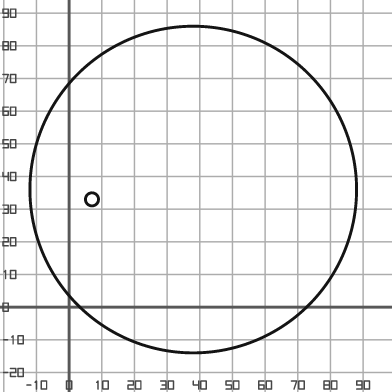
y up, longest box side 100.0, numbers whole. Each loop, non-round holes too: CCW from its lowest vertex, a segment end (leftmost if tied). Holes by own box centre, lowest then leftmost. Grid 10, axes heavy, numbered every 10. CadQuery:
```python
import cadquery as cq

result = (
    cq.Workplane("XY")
    .moveTo(38.0, 36.0)
    .circle(50.0)
    .moveTo(7.0, 33.0)
    .circle(2.0)
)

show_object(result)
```